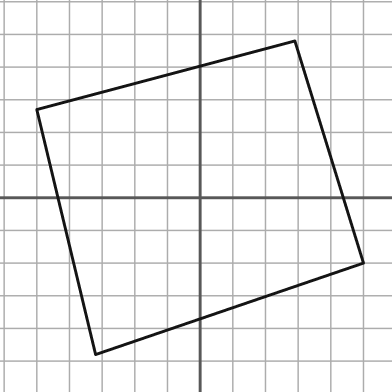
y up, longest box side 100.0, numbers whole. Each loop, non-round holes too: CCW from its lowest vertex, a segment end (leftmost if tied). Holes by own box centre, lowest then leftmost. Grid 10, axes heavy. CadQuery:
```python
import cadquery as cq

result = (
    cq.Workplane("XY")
    .moveTo(-32.0, -48.0)
    .lineTo(50.0, -20.0)
    .lineTo(29.0, 48.0)
    .lineTo(-50.0, 27.0)
    .close()
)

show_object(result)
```